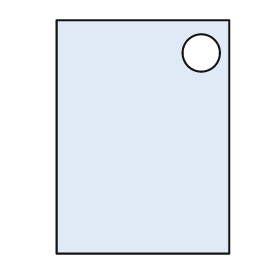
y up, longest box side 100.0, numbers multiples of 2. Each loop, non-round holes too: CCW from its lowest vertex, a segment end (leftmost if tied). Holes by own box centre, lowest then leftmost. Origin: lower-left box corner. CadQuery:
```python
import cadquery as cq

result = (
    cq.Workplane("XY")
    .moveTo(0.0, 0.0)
    .lineTo(74.0, 0.0)
    .lineTo(74.0, 100.0)
    .lineTo(0.0, 100.0)
    .close()
    .moveTo(62.0, 86.0)
    .circle(8.0)
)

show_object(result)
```